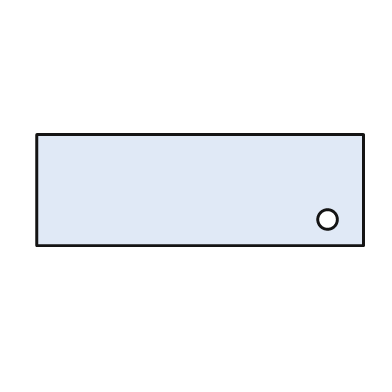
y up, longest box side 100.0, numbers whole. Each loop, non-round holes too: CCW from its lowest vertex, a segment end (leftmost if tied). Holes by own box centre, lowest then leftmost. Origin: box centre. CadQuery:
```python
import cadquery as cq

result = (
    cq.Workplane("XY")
    .moveTo(-50.0, -17.0)
    .lineTo(50.0, -17.0)
    .lineTo(50.0, 17.0)
    .lineTo(-50.0, 17.0)
    .close()
    .moveTo(39.0, -9.0)
    .circle(3.0)
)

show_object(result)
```